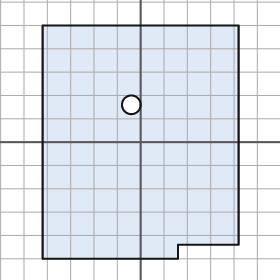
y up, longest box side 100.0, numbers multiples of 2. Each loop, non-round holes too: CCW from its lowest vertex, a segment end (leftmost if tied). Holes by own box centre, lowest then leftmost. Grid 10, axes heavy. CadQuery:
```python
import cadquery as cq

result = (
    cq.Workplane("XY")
    .moveTo(-42.0, -50.0)
    .lineTo(16.0, -50.0)
    .lineTo(16.0, -44.0)
    .lineTo(42.0, -44.0)
    .lineTo(42.0, 50.0)
    .lineTo(-42.0, 50.0)
    .close()
    .moveTo(-4.0, 16.0)
    .circle(4.0)
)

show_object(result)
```